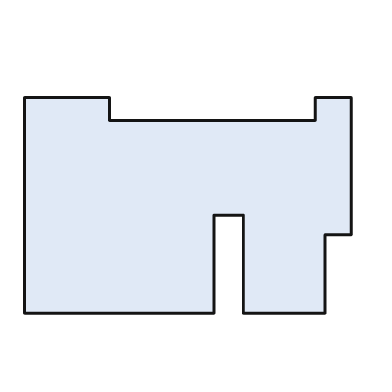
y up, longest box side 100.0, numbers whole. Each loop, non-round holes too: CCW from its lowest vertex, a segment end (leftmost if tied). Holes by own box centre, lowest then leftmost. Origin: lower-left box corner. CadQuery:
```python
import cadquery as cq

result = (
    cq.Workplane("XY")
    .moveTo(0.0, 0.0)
    .lineTo(58.0, 0.0)
    .lineTo(58.0, 30.0)
    .lineTo(67.0, 30.0)
    .lineTo(67.0, 0.0)
    .lineTo(92.0, 0.0)
    .lineTo(92.0, 24.0)
    .lineTo(100.0, 24.0)
    .lineTo(100.0, 66.0)
    .lineTo(89.0, 66.0)
    .lineTo(89.0, 59.0)
    .lineTo(26.0, 59.0)
    .lineTo(26.0, 66.0)
    .lineTo(0.0, 66.0)
    .close()
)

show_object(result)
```